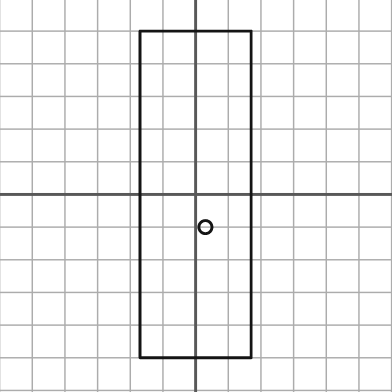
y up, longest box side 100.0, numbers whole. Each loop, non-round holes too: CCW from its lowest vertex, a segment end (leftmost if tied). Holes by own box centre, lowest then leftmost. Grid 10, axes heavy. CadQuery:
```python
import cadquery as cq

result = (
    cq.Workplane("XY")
    .moveTo(-17.0, -50.0)
    .lineTo(17.0, -50.0)
    .lineTo(17.0, 50.0)
    .lineTo(-17.0, 50.0)
    .close()
    .moveTo(3.0, -10.0)
    .circle(2.0)
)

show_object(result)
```